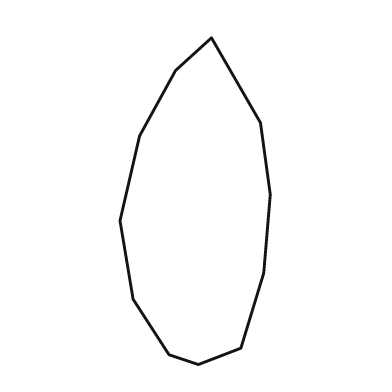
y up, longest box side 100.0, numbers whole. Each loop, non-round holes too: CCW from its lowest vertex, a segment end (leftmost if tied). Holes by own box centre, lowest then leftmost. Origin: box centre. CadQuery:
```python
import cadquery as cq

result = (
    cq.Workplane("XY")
    .moveTo(1.0, -50.0)
    .lineTo(14.0, -45.0)
    .lineTo(21.0, -22.0)
    .lineTo(23.0, 2.0)
    .lineTo(20.0, 24.0)
    .lineTo(5.0, 50.0)
    .lineTo(-6.0, 40.0)
    .lineTo(-17.0, 20.0)
    .lineTo(-23.0, -6.0)
    .lineTo(-19.0, -30.0)
    .lineTo(-8.0, -47.0)
    .close()
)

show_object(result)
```